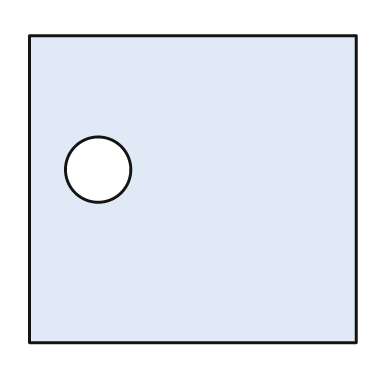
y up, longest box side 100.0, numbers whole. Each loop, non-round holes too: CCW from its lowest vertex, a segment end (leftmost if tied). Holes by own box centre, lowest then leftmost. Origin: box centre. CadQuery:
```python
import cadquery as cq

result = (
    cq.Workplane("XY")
    .moveTo(-50.0, -47.0)
    .lineTo(50.0, -47.0)
    .lineTo(50.0, 47.0)
    .lineTo(-50.0, 47.0)
    .close()
    .moveTo(-29.0, 6.0)
    .circle(10.0)
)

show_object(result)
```